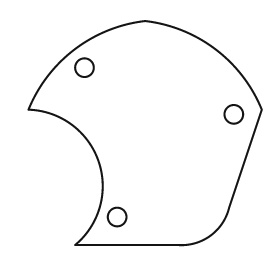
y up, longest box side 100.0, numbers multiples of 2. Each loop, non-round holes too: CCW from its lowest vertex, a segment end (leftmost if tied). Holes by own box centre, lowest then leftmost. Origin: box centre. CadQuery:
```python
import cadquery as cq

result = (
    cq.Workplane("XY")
    .moveTo(-30.0, -48.0)
    .lineTo(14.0, -48.0)
    .threePointArc((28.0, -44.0), (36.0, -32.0))
    .lineTo(50.0, 10.0)
    .threePointArc((30.0, 36.0), (0.0, 48.0))
    .threePointArc((-30.0, 36.0), (-50.0, 10.0))
    .threePointArc((-20.0, -12.0), (-30.0, -48.0))
    .close()
    .moveTo(-12.0, -36.0)
    .circle(4.0)
    .moveTo(38.0, 8.0)
    .circle(4.0)
    .moveTo(-26.0, 28.0)
    .circle(4.0)
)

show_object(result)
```